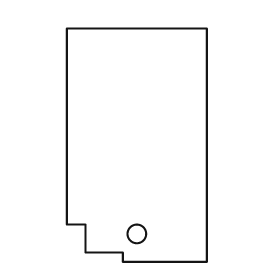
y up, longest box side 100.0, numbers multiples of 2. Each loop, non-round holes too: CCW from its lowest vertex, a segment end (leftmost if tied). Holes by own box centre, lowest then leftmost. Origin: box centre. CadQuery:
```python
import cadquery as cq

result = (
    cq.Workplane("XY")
    .moveTo(-6.0, -50.0)
    .lineTo(30.0, -50.0)
    .lineTo(30.0, 50.0)
    .lineTo(-30.0, 50.0)
    .lineTo(-30.0, -34.0)
    .lineTo(-22.0, -34.0)
    .lineTo(-22.0, -46.0)
    .lineTo(-6.0, -46.0)
    .close()
    .moveTo(0.0, -38.0)
    .circle(4.0)
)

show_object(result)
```